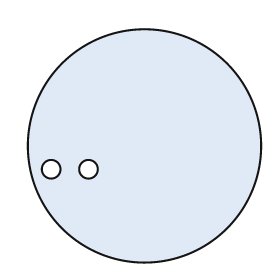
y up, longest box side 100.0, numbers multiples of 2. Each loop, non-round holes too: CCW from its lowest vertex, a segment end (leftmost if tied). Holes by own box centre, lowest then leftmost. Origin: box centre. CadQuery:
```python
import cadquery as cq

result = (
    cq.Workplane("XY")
    .moveTo(0.0, 0.0)
    .circle(50.0)
    .moveTo(-40.0, -10.0)
    .circle(4.0)
    .moveTo(-24.0, -10.0)
    .circle(4.0)
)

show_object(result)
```